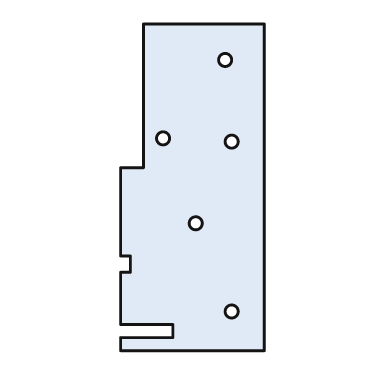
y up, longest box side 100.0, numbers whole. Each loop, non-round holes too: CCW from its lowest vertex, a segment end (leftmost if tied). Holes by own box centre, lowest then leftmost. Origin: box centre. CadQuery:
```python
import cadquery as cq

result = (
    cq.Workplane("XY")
    .moveTo(-22.0, -50.0)
    .lineTo(22.0, -50.0)
    .lineTo(22.0, 50.0)
    .lineTo(-15.0, 50.0)
    .lineTo(-15.0, 6.0)
    .lineTo(-22.0, 6.0)
    .lineTo(-22.0, -21.0)
    .lineTo(-19.0, -21.0)
    .lineTo(-19.0, -26.0)
    .lineTo(-22.0, -26.0)
    .lineTo(-22.0, -42.0)
    .lineTo(-6.0, -42.0)
    .lineTo(-6.0, -46.0)
    .lineTo(-22.0, -46.0)
    .close()
    .moveTo(12.0, -38.0)
    .circle(2.0)
    .moveTo(1.0, -11.0)
    .circle(2.0)
    .moveTo(12.0, 14.0)
    .circle(2.0)
    .moveTo(-9.0, 15.0)
    .circle(2.0)
    .moveTo(10.0, 39.0)
    .circle(2.0)
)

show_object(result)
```